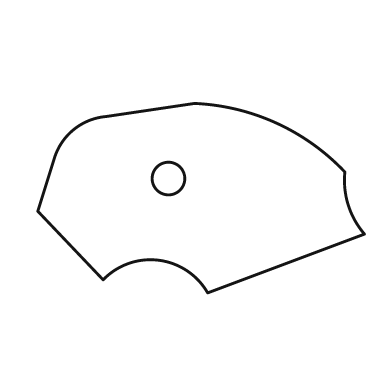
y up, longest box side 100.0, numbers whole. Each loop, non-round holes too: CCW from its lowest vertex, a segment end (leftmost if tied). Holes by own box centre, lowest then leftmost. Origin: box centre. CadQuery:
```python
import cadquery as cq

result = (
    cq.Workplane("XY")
    .moveTo(2.0, -29.0)
    .lineTo(50.0, -11.0)
    .threePointArc((45.0, -2.0), (44.0, 8.0))
    .threePointArc((23.0, 23.0), (-2.0, 29.0))
    .lineTo(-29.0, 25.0)
    .threePointArc((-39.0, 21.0), (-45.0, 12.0))
    .lineTo(-50.0, -4.0)
    .lineTo(-30.0, -25.0)
    .threePointArc((-13.0, -19.0), (2.0, -29.0))
    .close()
    .moveTo(-10.0, 6.0)
    .circle(5.0)
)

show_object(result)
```